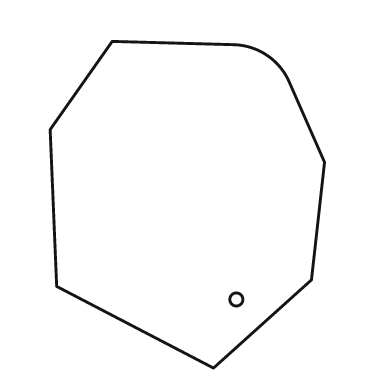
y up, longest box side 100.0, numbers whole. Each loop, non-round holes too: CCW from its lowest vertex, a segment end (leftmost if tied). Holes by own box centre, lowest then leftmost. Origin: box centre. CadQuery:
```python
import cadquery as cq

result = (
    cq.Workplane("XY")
    .moveTo(8.0, -50.0)
    .lineTo(38.0, -23.0)
    .lineTo(42.0, 13.0)
    .lineTo(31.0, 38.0)
    .threePointArc((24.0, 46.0), (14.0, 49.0))
    .lineTo(-23.0, 50.0)
    .lineTo(-42.0, 23.0)
    .lineTo(-40.0, -25.0)
    .close()
    .moveTo(15.0, -29.0)
    .circle(2.0)
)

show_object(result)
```